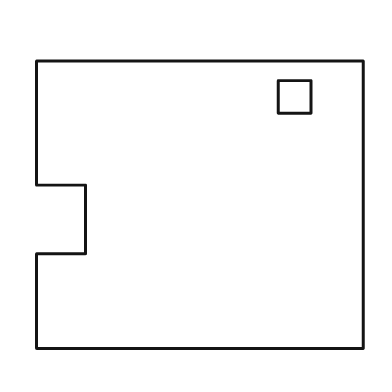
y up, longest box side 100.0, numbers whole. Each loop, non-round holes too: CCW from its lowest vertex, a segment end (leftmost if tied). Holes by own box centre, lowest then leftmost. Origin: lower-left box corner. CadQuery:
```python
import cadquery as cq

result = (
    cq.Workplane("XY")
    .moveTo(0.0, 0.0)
    .lineTo(100.0, 0.0)
    .lineTo(100.0, 88.0)
    .lineTo(0.0, 88.0)
    .lineTo(0.0, 50.0)
    .lineTo(15.0, 50.0)
    .lineTo(15.0, 29.0)
    .lineTo(0.0, 29.0)
    .close()
    .moveTo(74.0, 72.0)
    .lineTo(84.0, 72.0)
    .lineTo(84.0, 82.0)
    .lineTo(74.0, 82.0)
    .close()
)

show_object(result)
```